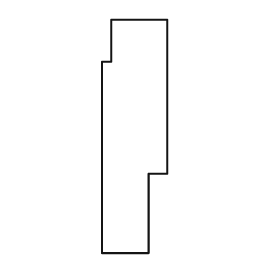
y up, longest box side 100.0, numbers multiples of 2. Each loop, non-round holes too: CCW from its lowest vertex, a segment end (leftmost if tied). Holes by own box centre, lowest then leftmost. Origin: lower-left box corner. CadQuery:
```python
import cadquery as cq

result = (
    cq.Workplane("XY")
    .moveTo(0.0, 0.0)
    .lineTo(20.0, 0.0)
    .lineTo(20.0, 34.0)
    .lineTo(28.0, 34.0)
    .lineTo(28.0, 100.0)
    .lineTo(4.0, 100.0)
    .lineTo(4.0, 82.0)
    .lineTo(0.0, 82.0)
    .close()
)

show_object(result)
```